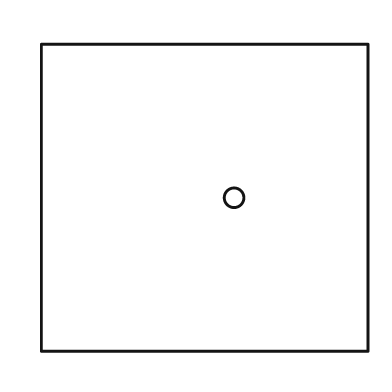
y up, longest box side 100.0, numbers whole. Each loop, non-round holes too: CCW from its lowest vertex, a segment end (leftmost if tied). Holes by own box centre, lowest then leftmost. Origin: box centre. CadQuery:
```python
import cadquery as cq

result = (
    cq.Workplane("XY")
    .moveTo(-50.0, -47.0)
    .lineTo(50.0, -47.0)
    .lineTo(50.0, 47.0)
    .lineTo(-50.0, 47.0)
    .close()
    .moveTo(9.0, 0.0)
    .circle(3.0)
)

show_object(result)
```